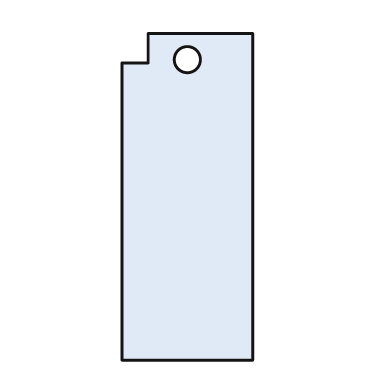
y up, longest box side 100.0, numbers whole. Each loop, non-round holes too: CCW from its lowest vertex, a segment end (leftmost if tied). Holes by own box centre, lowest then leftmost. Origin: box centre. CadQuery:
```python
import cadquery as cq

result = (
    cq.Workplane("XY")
    .moveTo(-20.0, -50.0)
    .lineTo(20.0, -50.0)
    .lineTo(20.0, 50.0)
    .lineTo(-12.0, 50.0)
    .lineTo(-12.0, 41.0)
    .lineTo(-20.0, 41.0)
    .close()
    .moveTo(0.0, 42.0)
    .circle(4.0)
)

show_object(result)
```